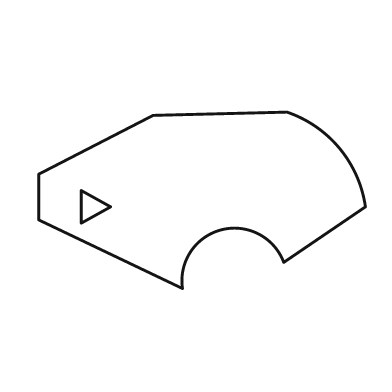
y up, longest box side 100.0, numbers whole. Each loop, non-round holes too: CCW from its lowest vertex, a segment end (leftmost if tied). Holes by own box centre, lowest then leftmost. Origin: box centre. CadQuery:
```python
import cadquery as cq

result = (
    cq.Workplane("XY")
    .moveTo(-6.0, -27.0)
    .threePointArc((6.0, -9.0), (25.0, -19.0))
    .lineTo(50.0, -2.0)
    .threePointArc((42.0, 16.0), (26.0, 27.0))
    .lineTo(-15.0, 26.0)
    .lineTo(-50.0, 8.0)
    .lineTo(-50.0, -6.0)
    .close()
    .moveTo(-37.0, -7.0)
    .lineTo(-28.0, -2.0)
    .lineTo(-37.0, 3.0)
    .close()
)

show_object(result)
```